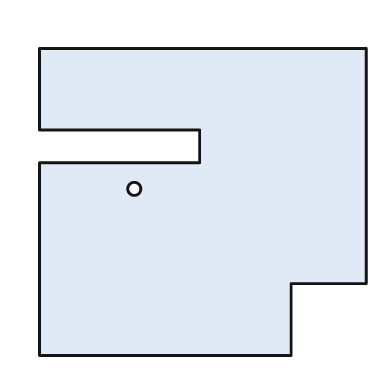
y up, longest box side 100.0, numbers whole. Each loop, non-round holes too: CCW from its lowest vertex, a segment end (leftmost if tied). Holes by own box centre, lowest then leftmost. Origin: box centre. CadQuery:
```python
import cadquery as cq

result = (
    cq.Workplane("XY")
    .moveTo(-50.0, -47.0)
    .lineTo(27.0, -47.0)
    .lineTo(27.0, -25.0)
    .lineTo(50.0, -25.0)
    .lineTo(50.0, 47.0)
    .lineTo(-50.0, 47.0)
    .lineTo(-50.0, 22.0)
    .lineTo(-1.0, 22.0)
    .lineTo(-1.0, 12.0)
    .lineTo(-50.0, 12.0)
    .close()
    .moveTo(-21.0, 4.0)
    .circle(2.0)
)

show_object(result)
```